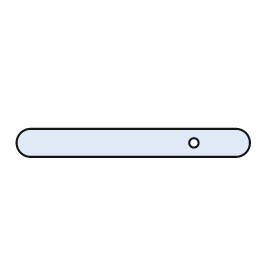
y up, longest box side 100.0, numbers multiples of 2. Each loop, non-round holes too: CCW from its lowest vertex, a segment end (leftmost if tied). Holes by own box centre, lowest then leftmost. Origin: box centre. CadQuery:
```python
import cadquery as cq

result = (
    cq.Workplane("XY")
    .moveTo(-44.0, -6.0)
    .lineTo(44.0, -6.0)
    .threePointArc((50.0, 0.0), (44.0, 6.0))
    .lineTo(-44.0, 6.0)
    .threePointArc((-50.0, 0.0), (-44.0, -6.0))
    .close()
    .moveTo(26.0, 0.0)
    .circle(2.0)
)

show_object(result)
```